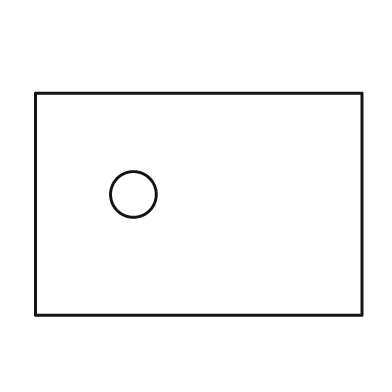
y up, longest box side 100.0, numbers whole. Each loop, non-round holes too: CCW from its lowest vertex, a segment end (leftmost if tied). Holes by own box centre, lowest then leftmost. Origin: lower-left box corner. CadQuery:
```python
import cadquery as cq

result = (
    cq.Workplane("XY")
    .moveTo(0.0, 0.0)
    .lineTo(100.0, 0.0)
    .lineTo(100.0, 68.0)
    .lineTo(0.0, 68.0)
    .close()
    .moveTo(30.0, 37.0)
    .circle(7.0)
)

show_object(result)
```